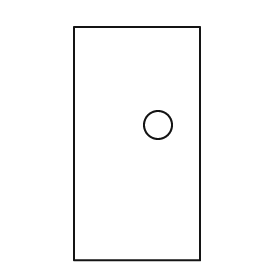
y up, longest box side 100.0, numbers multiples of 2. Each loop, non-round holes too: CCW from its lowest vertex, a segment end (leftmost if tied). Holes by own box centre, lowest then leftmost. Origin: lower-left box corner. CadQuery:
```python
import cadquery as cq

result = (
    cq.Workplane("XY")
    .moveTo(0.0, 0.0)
    .lineTo(54.0, 0.0)
    .lineTo(54.0, 100.0)
    .lineTo(0.0, 100.0)
    .close()
    .moveTo(36.0, 58.0)
    .circle(6.0)
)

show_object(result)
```